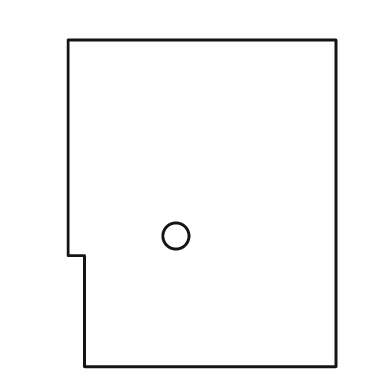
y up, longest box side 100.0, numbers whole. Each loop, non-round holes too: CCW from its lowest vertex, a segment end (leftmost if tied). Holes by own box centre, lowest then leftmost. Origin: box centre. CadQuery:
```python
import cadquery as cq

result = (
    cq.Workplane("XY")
    .moveTo(-36.0, -50.0)
    .lineTo(41.0, -50.0)
    .lineTo(41.0, 50.0)
    .lineTo(-41.0, 50.0)
    .lineTo(-41.0, -16.0)
    .lineTo(-36.0, -16.0)
    .close()
    .moveTo(-8.0, -10.0)
    .circle(4.0)
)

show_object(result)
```